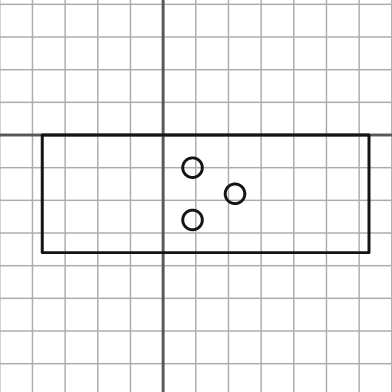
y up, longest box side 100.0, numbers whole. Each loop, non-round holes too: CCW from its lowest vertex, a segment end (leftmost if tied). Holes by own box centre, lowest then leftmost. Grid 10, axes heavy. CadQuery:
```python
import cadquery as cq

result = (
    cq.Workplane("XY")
    .moveTo(-37.0, -36.0)
    .lineTo(63.0, -36.0)
    .lineTo(63.0, 0.0)
    .lineTo(-37.0, 0.0)
    .close()
    .moveTo(9.0, -26.0)
    .circle(3.0)
    .moveTo(22.0, -18.0)
    .circle(3.0)
    .moveTo(9.0, -10.0)
    .circle(3.0)
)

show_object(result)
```